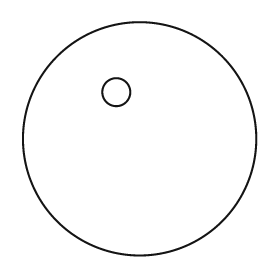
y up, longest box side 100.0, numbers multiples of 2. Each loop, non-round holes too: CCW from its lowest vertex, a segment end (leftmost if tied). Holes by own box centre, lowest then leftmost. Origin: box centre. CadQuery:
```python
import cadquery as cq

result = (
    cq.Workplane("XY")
    .moveTo(0.0, 0.0)
    .circle(50.0)
    .moveTo(-10.0, 20.0)
    .circle(6.0)
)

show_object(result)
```